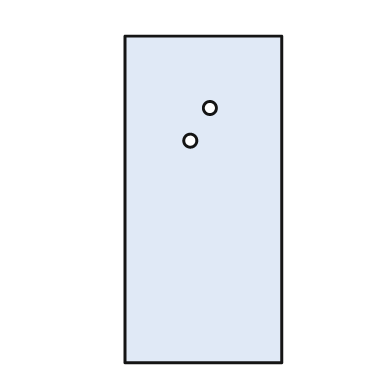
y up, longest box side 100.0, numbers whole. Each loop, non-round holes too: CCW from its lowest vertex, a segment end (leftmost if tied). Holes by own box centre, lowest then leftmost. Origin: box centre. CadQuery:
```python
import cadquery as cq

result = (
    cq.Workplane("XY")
    .moveTo(-24.0, -50.0)
    .lineTo(24.0, -50.0)
    .lineTo(24.0, 50.0)
    .lineTo(-24.0, 50.0)
    .close()
    .moveTo(-4.0, 18.0)
    .circle(2.0)
    .moveTo(2.0, 28.0)
    .circle(2.0)
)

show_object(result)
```